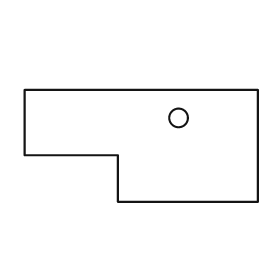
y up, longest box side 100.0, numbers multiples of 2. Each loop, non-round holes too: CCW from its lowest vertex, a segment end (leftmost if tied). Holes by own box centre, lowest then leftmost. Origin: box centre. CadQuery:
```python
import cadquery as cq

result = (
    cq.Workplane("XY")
    .moveTo(-10.0, -24.0)
    .lineTo(50.0, -24.0)
    .lineTo(50.0, 24.0)
    .lineTo(-50.0, 24.0)
    .lineTo(-50.0, -4.0)
    .lineTo(-10.0, -4.0)
    .close()
    .moveTo(16.0, 12.0)
    .circle(4.0)
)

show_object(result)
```